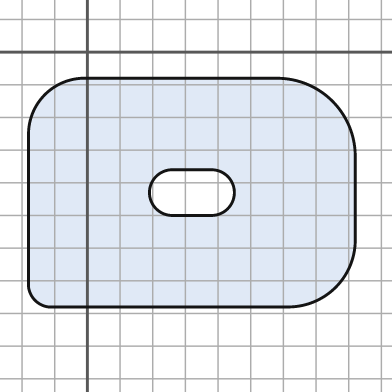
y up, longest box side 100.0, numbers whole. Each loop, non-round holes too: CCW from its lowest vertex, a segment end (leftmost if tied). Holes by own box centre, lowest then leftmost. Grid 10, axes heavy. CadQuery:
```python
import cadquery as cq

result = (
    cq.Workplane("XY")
    .moveTo(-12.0, -78.0)
    .lineTo(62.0, -78.0)
    .threePointArc((76.0, -72.0), (82.0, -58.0))
    .lineTo(82.0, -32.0)
    .threePointArc((75.0, -15.0), (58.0, -8.0))
    .lineTo(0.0, -8.0)
    .threePointArc((-13.0, -13.0), (-18.0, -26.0))
    .lineTo(-18.0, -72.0)
    .threePointArc((-16.0, -76.0), (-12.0, -78.0))
    .close()
    .moveTo(26.0, -50.0)
    .lineTo(38.0, -50.0)
    .threePointArc((45.0, -43.0), (38.0, -36.0))
    .lineTo(26.0, -36.0)
    .threePointArc((19.0, -43.0), (26.0, -50.0))
    .close()
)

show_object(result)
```